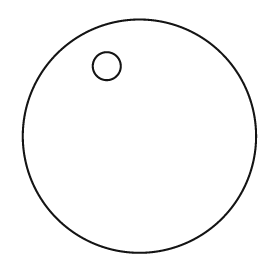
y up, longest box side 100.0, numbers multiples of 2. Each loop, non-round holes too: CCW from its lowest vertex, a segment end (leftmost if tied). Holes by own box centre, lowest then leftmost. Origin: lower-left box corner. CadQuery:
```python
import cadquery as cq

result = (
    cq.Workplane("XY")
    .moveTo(50.0, 50.0)
    .circle(50.0)
    .moveTo(36.0, 80.0)
    .circle(6.0)
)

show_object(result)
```